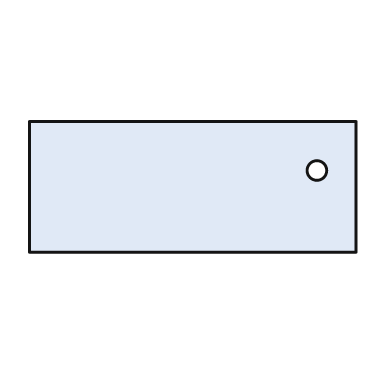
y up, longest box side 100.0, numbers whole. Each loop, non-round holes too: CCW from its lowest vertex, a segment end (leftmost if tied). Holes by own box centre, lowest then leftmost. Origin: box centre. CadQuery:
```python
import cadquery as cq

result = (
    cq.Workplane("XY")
    .moveTo(-50.0, -20.0)
    .lineTo(50.0, -20.0)
    .lineTo(50.0, 20.0)
    .lineTo(-50.0, 20.0)
    .close()
    .moveTo(38.0, 5.0)
    .circle(3.0)
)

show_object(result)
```